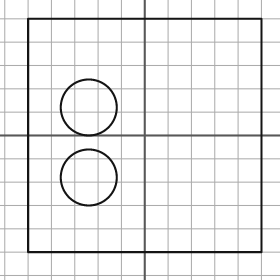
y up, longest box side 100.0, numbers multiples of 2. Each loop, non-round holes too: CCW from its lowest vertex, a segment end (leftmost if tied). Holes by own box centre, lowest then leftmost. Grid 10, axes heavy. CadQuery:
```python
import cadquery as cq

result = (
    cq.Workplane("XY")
    .moveTo(-50.0, -50.0)
    .lineTo(50.0, -50.0)
    .lineTo(50.0, 50.0)
    .lineTo(-50.0, 50.0)
    .close()
    .moveTo(-24.0, -18.0)
    .circle(12.0)
    .moveTo(-24.0, 12.0)
    .circle(12.0)
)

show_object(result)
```